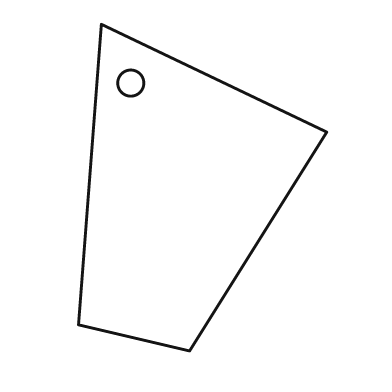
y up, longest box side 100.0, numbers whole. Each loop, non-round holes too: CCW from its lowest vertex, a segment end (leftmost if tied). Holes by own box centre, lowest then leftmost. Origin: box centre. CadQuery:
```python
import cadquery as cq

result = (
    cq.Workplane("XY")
    .moveTo(-4.0, -50.0)
    .lineTo(38.0, 17.0)
    .lineTo(-31.0, 50.0)
    .lineTo(-38.0, -42.0)
    .close()
    .moveTo(-22.0, 32.0)
    .circle(4.0)
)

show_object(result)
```